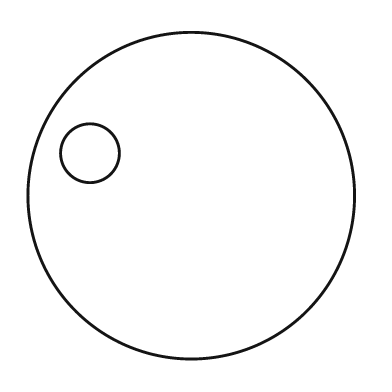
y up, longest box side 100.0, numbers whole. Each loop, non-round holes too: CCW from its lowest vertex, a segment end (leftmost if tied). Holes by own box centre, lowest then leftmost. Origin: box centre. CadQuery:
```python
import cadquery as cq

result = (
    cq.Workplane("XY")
    .moveTo(0.0, 0.0)
    .circle(50.0)
    .moveTo(-31.0, 13.0)
    .circle(9.0)
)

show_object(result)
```